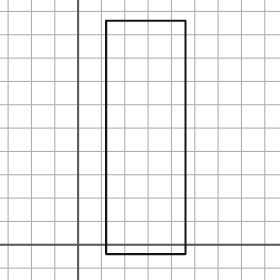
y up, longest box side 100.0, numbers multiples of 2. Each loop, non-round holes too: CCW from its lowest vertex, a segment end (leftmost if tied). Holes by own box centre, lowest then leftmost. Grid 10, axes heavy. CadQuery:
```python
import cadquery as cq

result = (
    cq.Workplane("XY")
    .moveTo(12.0, -4.0)
    .lineTo(46.0, -4.0)
    .lineTo(46.0, 96.0)
    .lineTo(12.0, 96.0)
    .close()
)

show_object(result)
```